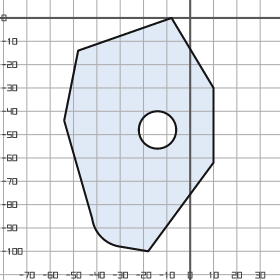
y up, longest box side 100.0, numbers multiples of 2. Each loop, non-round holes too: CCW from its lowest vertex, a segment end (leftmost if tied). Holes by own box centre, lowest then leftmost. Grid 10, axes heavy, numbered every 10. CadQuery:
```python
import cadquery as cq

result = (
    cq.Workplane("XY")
    .moveTo(-18.0, -100.0)
    .lineTo(10.0, -62.0)
    .lineTo(10.0, -30.0)
    .lineTo(-8.0, 0.0)
    .lineTo(-48.0, -14.0)
    .lineTo(-54.0, -44.0)
    .lineTo(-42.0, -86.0)
    .threePointArc((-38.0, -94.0), (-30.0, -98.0))
    .close()
    .moveTo(-14.0, -48.0)
    .circle(8.0)
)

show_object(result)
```